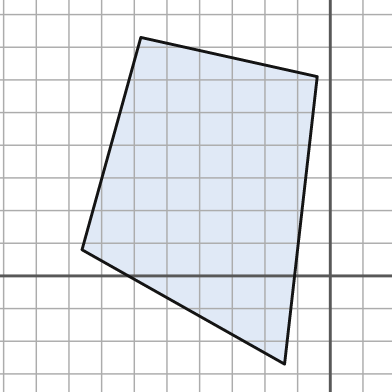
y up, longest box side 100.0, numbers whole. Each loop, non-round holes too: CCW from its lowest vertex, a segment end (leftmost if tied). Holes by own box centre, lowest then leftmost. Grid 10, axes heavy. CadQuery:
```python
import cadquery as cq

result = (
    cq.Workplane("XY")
    .moveTo(-14.0, -27.0)
    .lineTo(-4.0, 61.0)
    .lineTo(-58.0, 73.0)
    .lineTo(-76.0, 8.0)
    .close()
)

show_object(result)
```